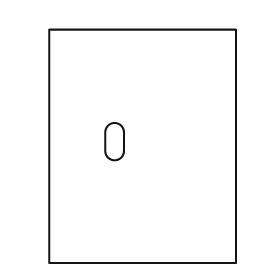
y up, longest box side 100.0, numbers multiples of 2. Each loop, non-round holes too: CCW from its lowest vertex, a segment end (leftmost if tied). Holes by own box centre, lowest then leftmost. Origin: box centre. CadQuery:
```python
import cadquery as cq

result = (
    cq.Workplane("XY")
    .moveTo(-40.0, -50.0)
    .lineTo(40.0, -50.0)
    .lineTo(40.0, 50.0)
    .lineTo(-40.0, 50.0)
    .close()
    .moveTo(-16.0, -2.0)
    .threePointArc((-12.0, -6.0), (-8.0, -2.0))
    .lineTo(-8.0, 6.0)
    .threePointArc((-12.0, 10.0), (-16.0, 6.0))
    .close()
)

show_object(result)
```